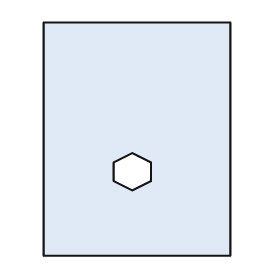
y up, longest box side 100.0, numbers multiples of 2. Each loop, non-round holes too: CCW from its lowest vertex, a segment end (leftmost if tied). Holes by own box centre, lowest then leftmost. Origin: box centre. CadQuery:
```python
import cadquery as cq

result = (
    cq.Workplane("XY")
    .moveTo(-40.0, -50.0)
    .lineTo(40.0, -50.0)
    .lineTo(40.0, 50.0)
    .lineTo(-40.0, 50.0)
    .close()
    .moveTo(-2.0, -22.0)
    .lineTo(6.0, -18.0)
    .lineTo(6.0, -10.0)
    .lineTo(-2.0, -6.0)
    .lineTo(-10.0, -10.0)
    .lineTo(-10.0, -18.0)
    .close()
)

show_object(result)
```